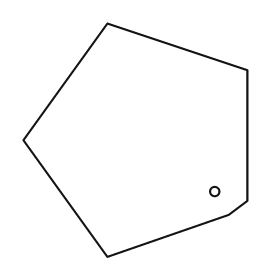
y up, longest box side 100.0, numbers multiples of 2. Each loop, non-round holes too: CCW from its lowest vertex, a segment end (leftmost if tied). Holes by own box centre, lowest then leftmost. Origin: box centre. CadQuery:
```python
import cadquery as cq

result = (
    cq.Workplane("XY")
    .moveTo(-12.0, -50.0)
    .lineTo(40.0, -32.0)
    .lineTo(48.0, -26.0)
    .lineTo(48.0, 30.0)
    .lineTo(-12.0, 50.0)
    .lineTo(-48.0, 0.0)
    .close()
    .moveTo(34.0, -22.0)
    .circle(2.0)
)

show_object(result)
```